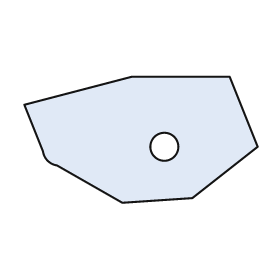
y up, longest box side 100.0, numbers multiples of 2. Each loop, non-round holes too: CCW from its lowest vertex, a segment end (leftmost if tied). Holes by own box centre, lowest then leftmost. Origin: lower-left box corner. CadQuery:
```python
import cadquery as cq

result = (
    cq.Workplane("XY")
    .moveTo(42.0, 0.0)
    .lineTo(72.0, 2.0)
    .lineTo(100.0, 24.0)
    .lineTo(88.0, 54.0)
    .lineTo(46.0, 54.0)
    .lineTo(0.0, 42.0)
    .lineTo(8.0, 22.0)
    .threePointArc((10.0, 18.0), (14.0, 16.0))
    .close()
    .moveTo(60.0, 24.0)
    .circle(6.0)
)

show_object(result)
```